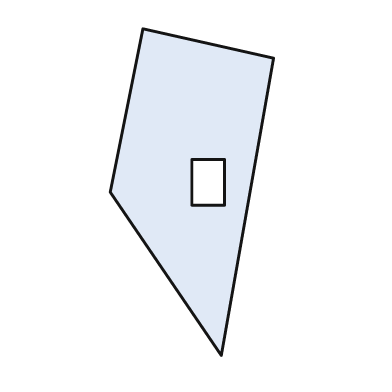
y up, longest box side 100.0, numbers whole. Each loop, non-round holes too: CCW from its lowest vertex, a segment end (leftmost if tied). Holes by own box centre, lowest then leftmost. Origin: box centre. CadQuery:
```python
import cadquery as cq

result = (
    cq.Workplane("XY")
    .moveTo(9.0, -50.0)
    .lineTo(25.0, 41.0)
    .lineTo(-15.0, 50.0)
    .lineTo(-25.0, 0.0)
    .close()
    .moveTo(0.0, -4.0)
    .lineTo(10.0, -4.0)
    .lineTo(10.0, 10.0)
    .lineTo(0.0, 10.0)
    .close()
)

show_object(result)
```